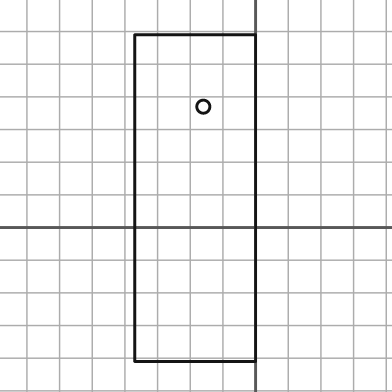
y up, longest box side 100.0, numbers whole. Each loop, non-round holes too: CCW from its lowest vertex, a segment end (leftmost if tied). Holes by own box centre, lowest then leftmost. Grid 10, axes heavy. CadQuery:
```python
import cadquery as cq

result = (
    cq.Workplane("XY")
    .moveTo(-37.0, -41.0)
    .lineTo(0.0, -41.0)
    .lineTo(0.0, 59.0)
    .lineTo(-37.0, 59.0)
    .close()
    .moveTo(-16.0, 37.0)
    .circle(2.0)
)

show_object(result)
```